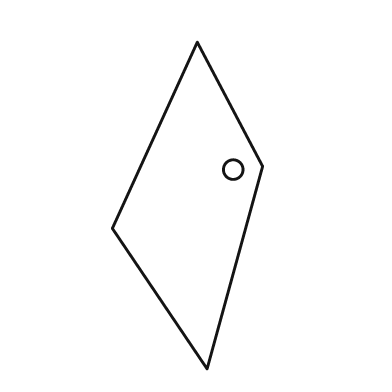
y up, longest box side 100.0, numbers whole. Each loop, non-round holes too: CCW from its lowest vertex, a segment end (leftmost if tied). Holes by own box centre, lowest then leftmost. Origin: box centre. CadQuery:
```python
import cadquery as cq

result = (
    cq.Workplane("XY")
    .moveTo(6.0, -50.0)
    .lineTo(23.0, 12.0)
    .lineTo(3.0, 50.0)
    .lineTo(-23.0, -7.0)
    .close()
    .moveTo(14.0, 11.0)
    .circle(3.0)
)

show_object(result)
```